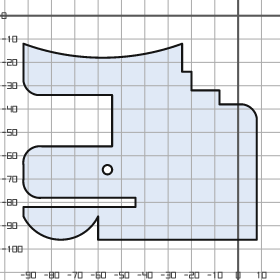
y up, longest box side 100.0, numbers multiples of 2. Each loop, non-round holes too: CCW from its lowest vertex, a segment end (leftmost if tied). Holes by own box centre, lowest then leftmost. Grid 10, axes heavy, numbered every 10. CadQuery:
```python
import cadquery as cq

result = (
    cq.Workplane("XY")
    .moveTo(-60.0, -96.0)
    .lineTo(8.0, -96.0)
    .lineTo(8.0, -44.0)
    .threePointArc((6.0, -40.0), (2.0, -38.0))
    .lineTo(-8.0, -38.0)
    .lineTo(-8.0, -32.0)
    .lineTo(-20.0, -32.0)
    .lineTo(-20.0, -24.0)
    .lineTo(-24.0, -24.0)
    .lineTo(-24.0, -12.0)
    .threePointArc((-58.0, -18.0), (-92.0, -12.0))
    .lineTo(-92.0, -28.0)
    .threePointArc((-90.0, -32.0), (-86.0, -34.0))
    .lineTo(-54.0, -34.0)
    .lineTo(-54.0, -56.0)
    .lineTo(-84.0, -56.0)
    .threePointArc((-90.0, -58.0), (-92.0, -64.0))
    .lineTo(-92.0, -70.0)
    .threePointArc((-90.0, -76.0), (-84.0, -78.0))
    .lineTo(-44.0, -78.0)
    .lineTo(-44.0, -82.0)
    .lineTo(-92.0, -82.0)
    .lineTo(-92.0, -86.0)
    .threePointArc((-76.0, -96.0), (-60.0, -86.0))
    .close()
    .moveTo(-56.0, -66.0)
    .circle(2.0)
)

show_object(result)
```